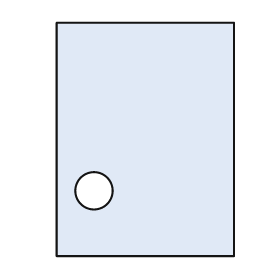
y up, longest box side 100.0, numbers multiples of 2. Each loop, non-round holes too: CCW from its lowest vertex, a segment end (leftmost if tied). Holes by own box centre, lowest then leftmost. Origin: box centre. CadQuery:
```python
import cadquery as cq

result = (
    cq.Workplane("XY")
    .moveTo(-38.0, -50.0)
    .lineTo(38.0, -50.0)
    .lineTo(38.0, 50.0)
    .lineTo(-38.0, 50.0)
    .close()
    .moveTo(-22.0, -22.0)
    .circle(8.0)
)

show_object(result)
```